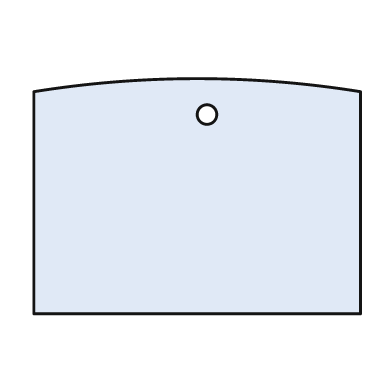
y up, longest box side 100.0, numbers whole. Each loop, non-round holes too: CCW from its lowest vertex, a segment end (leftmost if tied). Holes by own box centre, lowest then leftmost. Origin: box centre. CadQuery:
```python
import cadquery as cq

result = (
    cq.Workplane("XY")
    .moveTo(-50.0, -36.0)
    .lineTo(50.0, -36.0)
    .lineTo(50.0, 32.0)
    .threePointArc((0.0, 36.0), (-50.0, 32.0))
    .close()
    .moveTo(3.0, 25.0)
    .circle(3.0)
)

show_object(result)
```